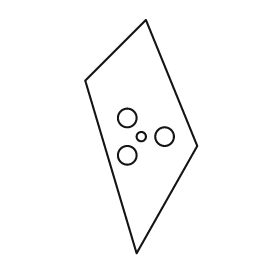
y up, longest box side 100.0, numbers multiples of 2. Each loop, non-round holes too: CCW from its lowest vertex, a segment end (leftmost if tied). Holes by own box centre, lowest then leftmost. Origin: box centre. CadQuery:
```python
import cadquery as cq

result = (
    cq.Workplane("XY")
    .moveTo(-2.0, -50.0)
    .lineTo(24.0, -4.0)
    .lineTo(2.0, 50.0)
    .lineTo(-24.0, 24.0)
    .close()
    .moveTo(-6.0, -8.0)
    .circle(4.0)
    .moveTo(0.0, 0.0)
    .circle(2.0)
    .moveTo(10.0, 0.0)
    .circle(4.0)
    .moveTo(-6.0, 8.0)
    .circle(4.0)
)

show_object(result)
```